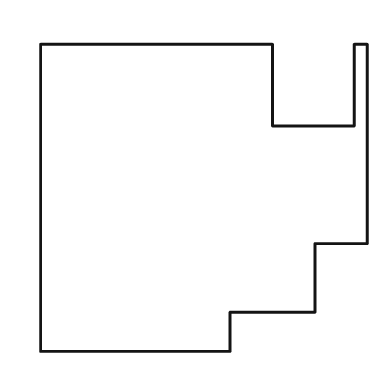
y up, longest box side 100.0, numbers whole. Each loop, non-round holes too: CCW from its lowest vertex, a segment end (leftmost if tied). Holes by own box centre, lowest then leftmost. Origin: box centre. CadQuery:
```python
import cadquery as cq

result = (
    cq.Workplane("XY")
    .moveTo(-50.0, -47.0)
    .lineTo(8.0, -47.0)
    .lineTo(8.0, -35.0)
    .lineTo(34.0, -35.0)
    .lineTo(34.0, -14.0)
    .lineTo(50.0, -14.0)
    .lineTo(50.0, 47.0)
    .lineTo(46.0, 47.0)
    .lineTo(46.0, 22.0)
    .lineTo(21.0, 22.0)
    .lineTo(21.0, 47.0)
    .lineTo(-50.0, 47.0)
    .close()
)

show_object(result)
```